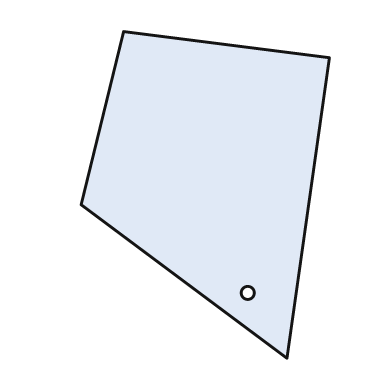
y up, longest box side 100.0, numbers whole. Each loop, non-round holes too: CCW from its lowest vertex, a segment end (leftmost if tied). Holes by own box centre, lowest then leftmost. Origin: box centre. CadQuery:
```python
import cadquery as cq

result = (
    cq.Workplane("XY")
    .moveTo(25.0, -50.0)
    .lineTo(38.0, 42.0)
    .lineTo(-25.0, 50.0)
    .lineTo(-38.0, -3.0)
    .close()
    .moveTo(13.0, -30.0)
    .circle(2.0)
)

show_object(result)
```